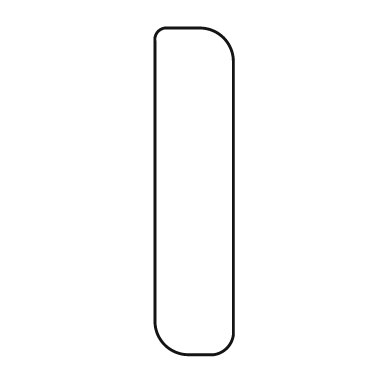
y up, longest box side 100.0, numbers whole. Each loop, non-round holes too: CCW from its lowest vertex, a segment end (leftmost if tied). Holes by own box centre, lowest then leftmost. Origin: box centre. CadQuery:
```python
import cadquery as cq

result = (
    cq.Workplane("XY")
    .moveTo(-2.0, -50.0)
    .lineTo(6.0, -50.0)
    .threePointArc((10.0, -48.0), (12.0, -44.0))
    .lineTo(12.0, 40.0)
    .threePointArc((9.0, 47.0), (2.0, 50.0))
    .lineTo(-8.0, 50.0)
    .threePointArc((-11.0, 49.0), (-12.0, 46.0))
    .lineTo(-12.0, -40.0)
    .threePointArc((-9.0, -47.0), (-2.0, -50.0))
    .close()
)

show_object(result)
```